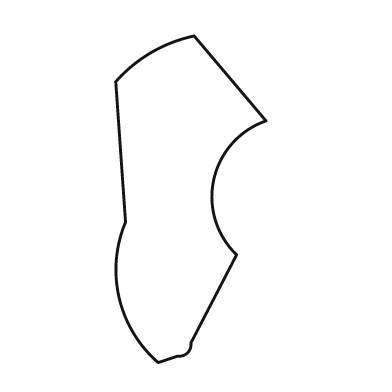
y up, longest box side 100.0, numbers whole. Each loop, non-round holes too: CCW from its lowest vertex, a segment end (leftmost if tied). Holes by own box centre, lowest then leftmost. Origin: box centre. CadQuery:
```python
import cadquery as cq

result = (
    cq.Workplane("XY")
    .moveTo(-10.0, -50.0)
    .lineTo(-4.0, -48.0)
    .threePointArc((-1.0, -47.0), (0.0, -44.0))
    .lineTo(14.0, -17.0)
    .threePointArc((7.0, 6.0), (23.0, 24.0))
    .lineTo(1.0, 50.0)
    .threePointArc((-12.0, 45.0), (-23.0, 36.0))
    .lineTo(-20.0, -7.0)
    .threePointArc((-22.0, -30.0), (-10.0, -50.0))
    .close()
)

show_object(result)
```